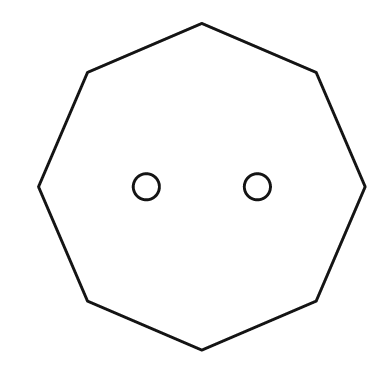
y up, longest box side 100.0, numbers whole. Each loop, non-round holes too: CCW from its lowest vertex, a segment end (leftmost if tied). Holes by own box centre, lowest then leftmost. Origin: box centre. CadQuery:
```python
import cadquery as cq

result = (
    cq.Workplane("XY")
    .moveTo(0.0, -50.0)
    .lineTo(35.0, -35.0)
    .lineTo(50.0, 0.0)
    .lineTo(35.0, 35.0)
    .lineTo(0.0, 50.0)
    .lineTo(-35.0, 35.0)
    .lineTo(-50.0, 0.0)
    .lineTo(-35.0, -35.0)
    .close()
    .moveTo(-17.0, 0.0)
    .circle(4.0)
    .moveTo(17.0, 0.0)
    .circle(4.0)
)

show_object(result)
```